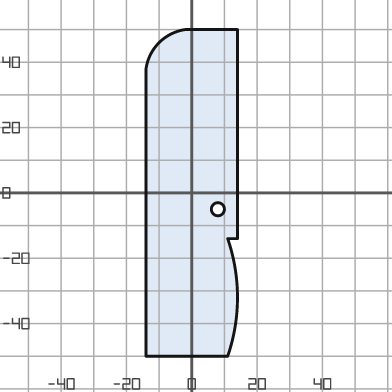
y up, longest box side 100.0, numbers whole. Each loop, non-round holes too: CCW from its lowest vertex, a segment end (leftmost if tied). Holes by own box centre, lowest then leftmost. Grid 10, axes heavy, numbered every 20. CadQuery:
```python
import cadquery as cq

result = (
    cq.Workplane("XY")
    .moveTo(-14.0, -50.0)
    .lineTo(11.0, -50.0)
    .threePointArc((14.0, -32.0), (11.0, -14.0))
    .lineTo(14.0, -14.0)
    .lineTo(14.0, 50.0)
    .lineTo(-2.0, 50.0)
    .threePointArc((-10.0, 46.0), (-14.0, 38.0))
    .close()
    .moveTo(8.0, -5.0)
    .circle(2.0)
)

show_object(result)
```